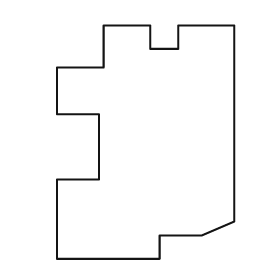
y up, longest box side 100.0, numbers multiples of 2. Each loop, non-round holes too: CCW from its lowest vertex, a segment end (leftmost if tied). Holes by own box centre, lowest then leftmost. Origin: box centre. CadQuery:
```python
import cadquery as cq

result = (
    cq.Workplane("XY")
    .moveTo(-38.0, -50.0)
    .lineTo(6.0, -50.0)
    .lineTo(6.0, -40.0)
    .lineTo(24.0, -40.0)
    .lineTo(38.0, -34.0)
    .lineTo(38.0, 50.0)
    .lineTo(14.0, 50.0)
    .lineTo(14.0, 40.0)
    .lineTo(2.0, 40.0)
    .lineTo(2.0, 50.0)
    .lineTo(-18.0, 50.0)
    .lineTo(-18.0, 32.0)
    .lineTo(-38.0, 32.0)
    .lineTo(-38.0, 12.0)
    .lineTo(-20.0, 12.0)
    .lineTo(-20.0, -16.0)
    .lineTo(-38.0, -16.0)
    .close()
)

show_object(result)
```